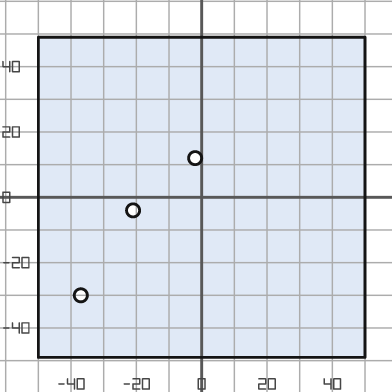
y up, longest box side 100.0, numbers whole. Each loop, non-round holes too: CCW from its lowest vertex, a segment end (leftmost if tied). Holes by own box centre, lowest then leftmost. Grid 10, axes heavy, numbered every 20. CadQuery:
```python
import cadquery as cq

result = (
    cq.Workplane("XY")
    .moveTo(-50.0, -49.0)
    .lineTo(50.0, -49.0)
    .lineTo(50.0, 49.0)
    .lineTo(-50.0, 49.0)
    .close()
    .moveTo(-37.0, -30.0)
    .circle(2.0)
    .moveTo(-21.0, -4.0)
    .circle(2.0)
    .moveTo(-2.0, 12.0)
    .circle(2.0)
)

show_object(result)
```